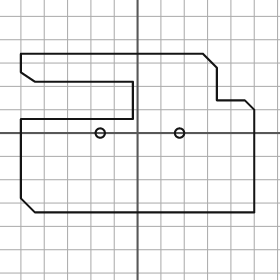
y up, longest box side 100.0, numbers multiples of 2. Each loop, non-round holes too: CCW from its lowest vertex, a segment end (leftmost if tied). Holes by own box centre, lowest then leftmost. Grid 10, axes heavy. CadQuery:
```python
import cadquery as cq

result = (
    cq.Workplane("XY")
    .moveTo(-44.0, -34.0)
    .lineTo(50.0, -34.0)
    .lineTo(50.0, 10.0)
    .lineTo(46.0, 14.0)
    .lineTo(34.0, 14.0)
    .lineTo(34.0, 28.0)
    .lineTo(28.0, 34.0)
    .lineTo(-50.0, 34.0)
    .lineTo(-50.0, 26.0)
    .lineTo(-44.0, 22.0)
    .lineTo(-2.0, 22.0)
    .lineTo(-2.0, 6.0)
    .lineTo(-50.0, 6.0)
    .lineTo(-50.0, -28.0)
    .close()
    .moveTo(-16.0, 0.0)
    .circle(2.0)
    .moveTo(18.0, 0.0)
    .circle(2.0)
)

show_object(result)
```